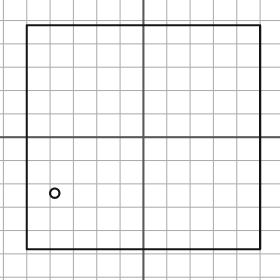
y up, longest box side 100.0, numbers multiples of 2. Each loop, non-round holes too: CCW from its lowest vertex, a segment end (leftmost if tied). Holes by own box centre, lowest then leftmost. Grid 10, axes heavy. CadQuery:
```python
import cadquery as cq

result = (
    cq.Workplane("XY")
    .moveTo(-50.0, -48.0)
    .lineTo(50.0, -48.0)
    .lineTo(50.0, 48.0)
    .lineTo(-50.0, 48.0)
    .close()
    .moveTo(-38.0, -24.0)
    .circle(2.0)
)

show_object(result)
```